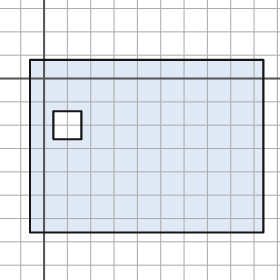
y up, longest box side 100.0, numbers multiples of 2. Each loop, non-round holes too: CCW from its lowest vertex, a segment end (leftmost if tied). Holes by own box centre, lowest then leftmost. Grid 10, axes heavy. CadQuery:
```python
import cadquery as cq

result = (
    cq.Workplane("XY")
    .moveTo(-6.0, -66.0)
    .lineTo(94.0, -66.0)
    .lineTo(94.0, 8.0)
    .lineTo(-6.0, 8.0)
    .close()
    .moveTo(4.0, -26.0)
    .lineTo(16.0, -26.0)
    .lineTo(16.0, -14.0)
    .lineTo(4.0, -14.0)
    .close()
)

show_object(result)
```